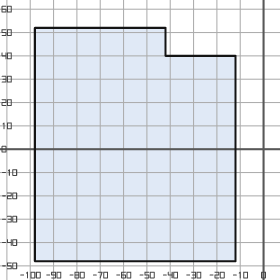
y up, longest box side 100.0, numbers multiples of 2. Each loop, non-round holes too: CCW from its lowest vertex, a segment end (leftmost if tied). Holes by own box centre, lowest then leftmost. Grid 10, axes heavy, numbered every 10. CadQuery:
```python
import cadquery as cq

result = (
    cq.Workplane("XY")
    .moveTo(-98.0, -48.0)
    .lineTo(-12.0, -48.0)
    .lineTo(-12.0, 40.0)
    .lineTo(-42.0, 40.0)
    .lineTo(-42.0, 52.0)
    .lineTo(-98.0, 52.0)
    .close()
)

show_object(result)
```